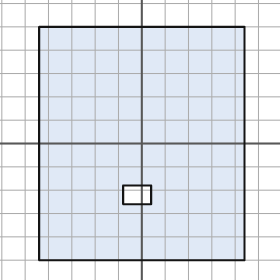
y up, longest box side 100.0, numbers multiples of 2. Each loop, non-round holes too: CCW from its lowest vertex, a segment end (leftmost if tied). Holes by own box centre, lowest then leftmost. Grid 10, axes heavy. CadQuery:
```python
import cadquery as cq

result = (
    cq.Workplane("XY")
    .moveTo(-44.0, -50.0)
    .lineTo(44.0, -50.0)
    .lineTo(44.0, 50.0)
    .lineTo(-44.0, 50.0)
    .close()
    .moveTo(-8.0, -26.0)
    .lineTo(4.0, -26.0)
    .lineTo(4.0, -18.0)
    .lineTo(-8.0, -18.0)
    .close()
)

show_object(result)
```